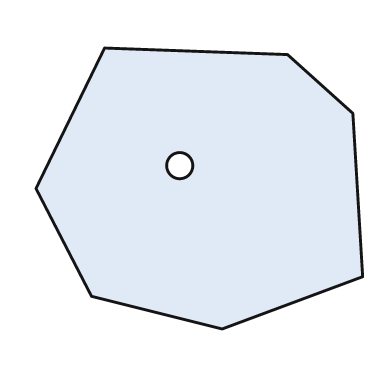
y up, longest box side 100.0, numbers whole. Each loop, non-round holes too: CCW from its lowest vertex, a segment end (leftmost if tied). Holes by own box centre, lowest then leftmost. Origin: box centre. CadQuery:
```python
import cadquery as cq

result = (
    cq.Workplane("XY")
    .moveTo(7.0, -43.0)
    .lineTo(50.0, -27.0)
    .lineTo(47.0, 23.0)
    .lineTo(27.0, 41.0)
    .lineTo(-29.0, 43.0)
    .lineTo(-50.0, 0.0)
    .lineTo(-33.0, -33.0)
    .close()
    .moveTo(-6.0, 7.0)
    .circle(4.0)
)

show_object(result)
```